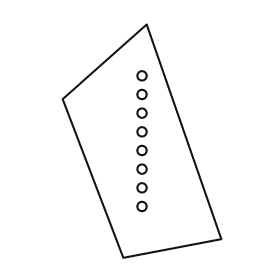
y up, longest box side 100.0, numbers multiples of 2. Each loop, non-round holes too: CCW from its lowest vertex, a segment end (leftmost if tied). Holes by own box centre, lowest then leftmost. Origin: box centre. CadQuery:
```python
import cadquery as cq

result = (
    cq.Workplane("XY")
    .moveTo(-8.0, -50.0)
    .lineTo(34.0, -42.0)
    .lineTo(2.0, 50.0)
    .lineTo(-34.0, 18.0)
    .close()
    .moveTo(0.0, -28.0)
    .circle(2.0)
    .moveTo(0.0, -20.0)
    .circle(2.0)
    .moveTo(0.0, -12.0)
    .circle(2.0)
    .moveTo(0.0, -4.0)
    .circle(2.0)
    .moveTo(0.0, 4.0)
    .circle(2.0)
    .moveTo(0.0, 12.0)
    .circle(2.0)
    .moveTo(0.0, 20.0)
    .circle(2.0)
    .moveTo(0.0, 28.0)
    .circle(2.0)
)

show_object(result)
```